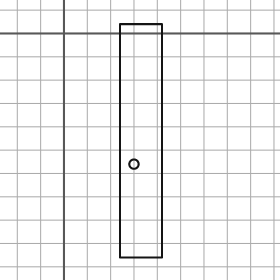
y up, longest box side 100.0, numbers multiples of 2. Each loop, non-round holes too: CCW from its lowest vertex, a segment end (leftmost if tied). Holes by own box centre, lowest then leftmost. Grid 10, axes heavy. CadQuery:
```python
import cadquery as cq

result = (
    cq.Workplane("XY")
    .moveTo(24.0, -96.0)
    .lineTo(42.0, -96.0)
    .lineTo(42.0, 4.0)
    .lineTo(24.0, 4.0)
    .close()
    .moveTo(30.0, -56.0)
    .circle(2.0)
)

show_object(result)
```